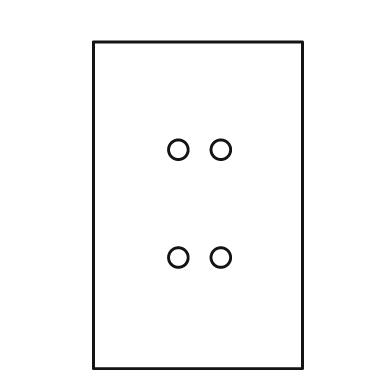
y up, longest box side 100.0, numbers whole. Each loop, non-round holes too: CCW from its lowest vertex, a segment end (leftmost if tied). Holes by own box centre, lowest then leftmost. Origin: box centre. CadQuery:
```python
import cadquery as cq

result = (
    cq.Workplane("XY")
    .moveTo(-32.0, -50.0)
    .lineTo(32.0, -50.0)
    .lineTo(32.0, 50.0)
    .lineTo(-32.0, 50.0)
    .close()
    .moveTo(-6.0, -16.0)
    .circle(3.0)
    .moveTo(7.0, -16.0)
    .circle(3.0)
    .moveTo(-6.0, 17.0)
    .circle(3.0)
    .moveTo(7.0, 17.0)
    .circle(3.0)
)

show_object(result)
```